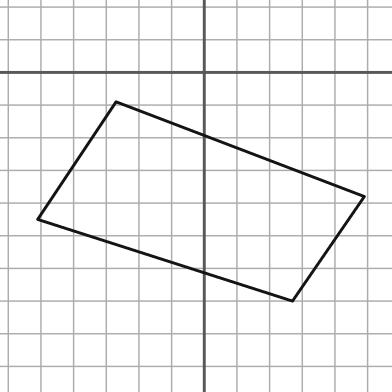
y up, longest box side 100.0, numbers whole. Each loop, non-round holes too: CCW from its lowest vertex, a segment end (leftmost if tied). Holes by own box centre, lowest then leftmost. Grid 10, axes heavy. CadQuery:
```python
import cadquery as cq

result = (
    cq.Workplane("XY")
    .moveTo(27.0, -70.0)
    .lineTo(49.0, -38.0)
    .lineTo(-27.0, -9.0)
    .lineTo(-51.0, -45.0)
    .close()
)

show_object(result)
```